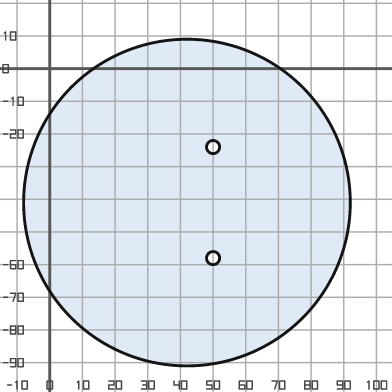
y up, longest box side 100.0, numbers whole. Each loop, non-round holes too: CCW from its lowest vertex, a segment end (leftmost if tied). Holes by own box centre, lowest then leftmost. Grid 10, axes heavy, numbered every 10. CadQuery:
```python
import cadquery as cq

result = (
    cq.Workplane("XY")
    .moveTo(42.0, -41.0)
    .circle(50.0)
    .moveTo(50.0, -58.0)
    .circle(2.0)
    .moveTo(50.0, -24.0)
    .circle(2.0)
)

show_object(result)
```